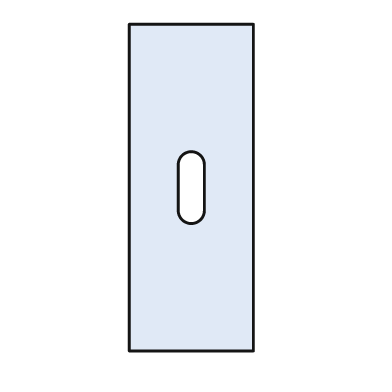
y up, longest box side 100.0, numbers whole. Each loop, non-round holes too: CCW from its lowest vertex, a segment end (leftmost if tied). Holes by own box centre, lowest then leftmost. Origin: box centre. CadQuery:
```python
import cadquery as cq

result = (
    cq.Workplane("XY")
    .moveTo(-19.0, -50.0)
    .lineTo(19.0, -50.0)
    .lineTo(19.0, 50.0)
    .lineTo(-19.0, 50.0)
    .close()
    .moveTo(-4.0, -7.0)
    .threePointArc((0.0, -11.0), (4.0, -7.0))
    .lineTo(4.0, 7.0)
    .threePointArc((0.0, 11.0), (-4.0, 7.0))
    .close()
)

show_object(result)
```